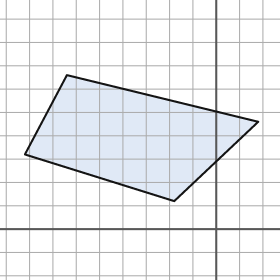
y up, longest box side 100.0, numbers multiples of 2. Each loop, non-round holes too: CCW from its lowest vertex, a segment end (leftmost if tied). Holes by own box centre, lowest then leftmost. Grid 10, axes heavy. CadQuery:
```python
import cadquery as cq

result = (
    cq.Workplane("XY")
    .moveTo(-18.0, 12.0)
    .lineTo(18.0, 46.0)
    .lineTo(-64.0, 66.0)
    .lineTo(-82.0, 32.0)
    .close()
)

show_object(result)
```